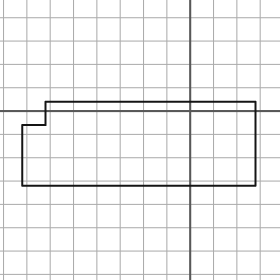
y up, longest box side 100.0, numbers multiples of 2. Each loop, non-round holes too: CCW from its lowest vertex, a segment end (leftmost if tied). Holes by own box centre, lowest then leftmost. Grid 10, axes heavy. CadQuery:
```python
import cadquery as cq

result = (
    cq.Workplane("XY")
    .moveTo(-72.0, -32.0)
    .lineTo(28.0, -32.0)
    .lineTo(28.0, 4.0)
    .lineTo(-62.0, 4.0)
    .lineTo(-62.0, -6.0)
    .lineTo(-72.0, -6.0)
    .close()
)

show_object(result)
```